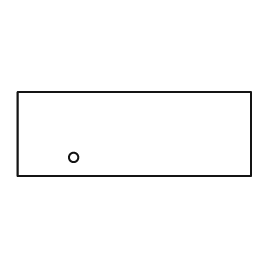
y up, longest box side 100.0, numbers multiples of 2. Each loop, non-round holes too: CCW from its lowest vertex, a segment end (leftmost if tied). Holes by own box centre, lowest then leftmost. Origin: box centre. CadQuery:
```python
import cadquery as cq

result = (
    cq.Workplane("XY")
    .moveTo(-50.0, -18.0)
    .lineTo(50.0, -18.0)
    .lineTo(50.0, 18.0)
    .lineTo(-50.0, 18.0)
    .close()
    .moveTo(-26.0, -10.0)
    .circle(2.0)
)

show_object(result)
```